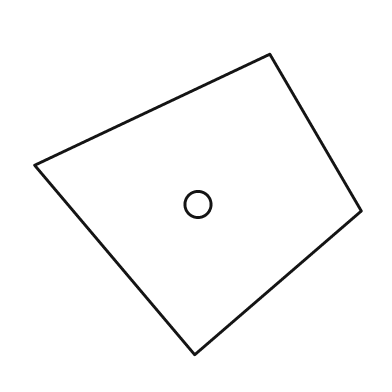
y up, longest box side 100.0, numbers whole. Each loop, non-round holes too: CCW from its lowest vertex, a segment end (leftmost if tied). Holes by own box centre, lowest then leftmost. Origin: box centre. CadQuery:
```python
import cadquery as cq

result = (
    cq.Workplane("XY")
    .moveTo(-1.0, -46.0)
    .lineTo(50.0, -2.0)
    .lineTo(22.0, 46.0)
    .lineTo(-50.0, 12.0)
    .close()
    .moveTo(0.0, 0.0)
    .circle(4.0)
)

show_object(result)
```